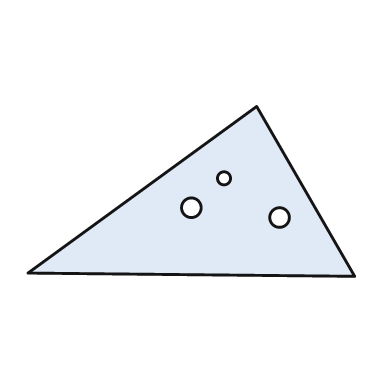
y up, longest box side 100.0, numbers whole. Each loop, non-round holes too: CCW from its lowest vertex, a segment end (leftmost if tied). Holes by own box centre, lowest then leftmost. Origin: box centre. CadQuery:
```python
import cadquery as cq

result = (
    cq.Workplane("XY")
    .moveTo(50.0, -26.0)
    .lineTo(20.0, 26.0)
    .lineTo(-50.0, -25.0)
    .close()
    .moveTo(27.0, -8.0)
    .circle(3.0)
    .moveTo(0.0, -5.0)
    .circle(3.0)
    .moveTo(10.0, 4.0)
    .circle(2.0)
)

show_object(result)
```